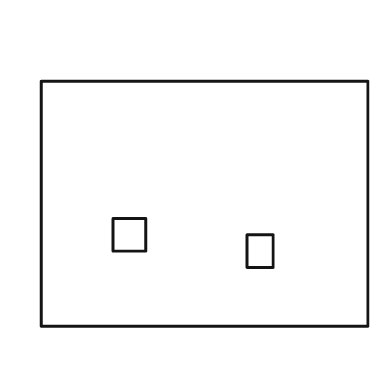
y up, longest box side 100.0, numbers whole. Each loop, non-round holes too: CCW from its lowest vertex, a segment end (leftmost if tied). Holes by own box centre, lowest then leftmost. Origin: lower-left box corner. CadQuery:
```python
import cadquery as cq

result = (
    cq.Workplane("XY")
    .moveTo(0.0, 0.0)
    .lineTo(100.0, 0.0)
    .lineTo(100.0, 75.0)
    .lineTo(0.0, 75.0)
    .close()
    .moveTo(63.0, 18.0)
    .lineTo(71.0, 18.0)
    .lineTo(71.0, 28.0)
    .lineTo(63.0, 28.0)
    .close()
    .moveTo(22.0, 23.0)
    .lineTo(32.0, 23.0)
    .lineTo(32.0, 33.0)
    .lineTo(22.0, 33.0)
    .close()
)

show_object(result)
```